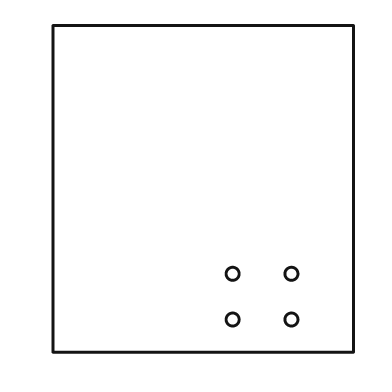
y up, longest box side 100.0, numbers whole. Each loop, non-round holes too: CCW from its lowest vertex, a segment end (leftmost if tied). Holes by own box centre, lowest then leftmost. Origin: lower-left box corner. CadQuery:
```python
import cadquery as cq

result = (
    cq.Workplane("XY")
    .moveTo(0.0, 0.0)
    .lineTo(92.0, 0.0)
    .lineTo(92.0, 100.0)
    .lineTo(0.0, 100.0)
    .close()
    .moveTo(55.0, 10.0)
    .circle(2.0)
    .moveTo(73.0, 10.0)
    .circle(2.0)
    .moveTo(55.0, 24.0)
    .circle(2.0)
    .moveTo(73.0, 24.0)
    .circle(2.0)
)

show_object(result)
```